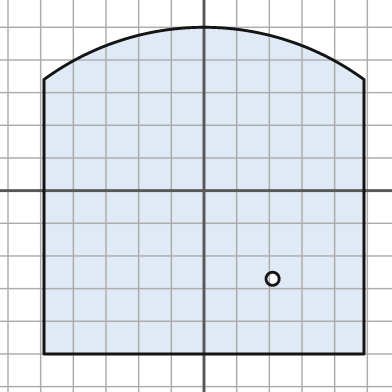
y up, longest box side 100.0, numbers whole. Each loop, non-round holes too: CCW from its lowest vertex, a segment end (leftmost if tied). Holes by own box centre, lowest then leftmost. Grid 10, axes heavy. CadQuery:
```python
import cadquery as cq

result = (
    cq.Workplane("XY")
    .moveTo(-49.0, -50.0)
    .lineTo(49.0, -50.0)
    .lineTo(49.0, 34.0)
    .threePointArc((0.0, 50.0), (-49.0, 34.0))
    .close()
    .moveTo(21.0, -27.0)
    .circle(2.0)
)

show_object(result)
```